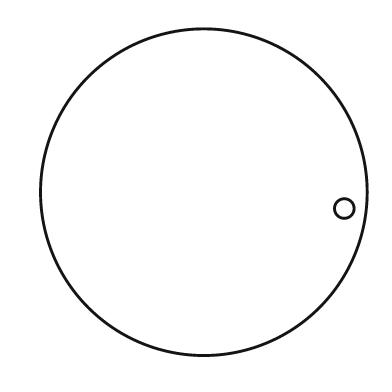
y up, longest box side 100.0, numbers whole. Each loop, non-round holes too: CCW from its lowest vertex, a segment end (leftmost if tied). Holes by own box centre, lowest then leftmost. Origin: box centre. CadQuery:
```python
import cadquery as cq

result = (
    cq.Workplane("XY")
    .moveTo(0.0, 0.0)
    .circle(50.0)
    .moveTo(43.0, -5.0)
    .circle(3.0)
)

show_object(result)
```